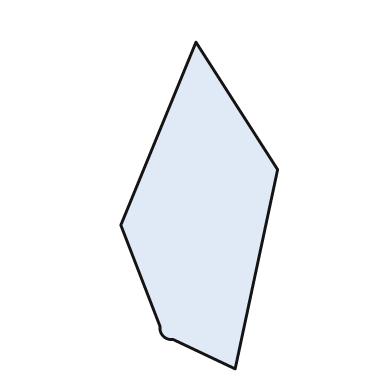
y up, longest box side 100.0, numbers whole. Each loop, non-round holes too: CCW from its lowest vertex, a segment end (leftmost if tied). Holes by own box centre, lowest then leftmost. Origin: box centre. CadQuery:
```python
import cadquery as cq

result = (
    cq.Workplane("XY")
    .moveTo(11.0, -50.0)
    .lineTo(24.0, 11.0)
    .lineTo(-1.0, 50.0)
    .lineTo(-24.0, -6.0)
    .lineTo(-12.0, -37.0)
    .threePointArc((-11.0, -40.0), (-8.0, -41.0))
    .close()
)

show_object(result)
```